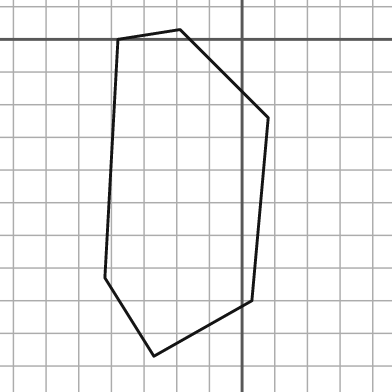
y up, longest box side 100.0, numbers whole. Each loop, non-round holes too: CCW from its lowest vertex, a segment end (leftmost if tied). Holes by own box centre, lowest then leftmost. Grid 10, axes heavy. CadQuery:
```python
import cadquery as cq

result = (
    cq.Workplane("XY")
    .moveTo(-27.0, -97.0)
    .lineTo(3.0, -80.0)
    .lineTo(8.0, -24.0)
    .lineTo(-19.0, 3.0)
    .lineTo(-38.0, 0.0)
    .lineTo(-42.0, -73.0)
    .close()
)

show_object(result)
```